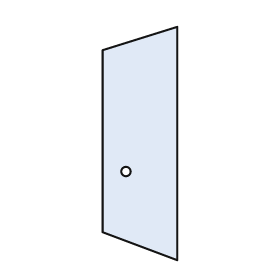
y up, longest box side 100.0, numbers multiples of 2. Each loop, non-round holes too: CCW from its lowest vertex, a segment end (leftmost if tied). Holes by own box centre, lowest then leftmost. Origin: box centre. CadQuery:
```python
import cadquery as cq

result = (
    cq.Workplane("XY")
    .moveTo(16.0, -50.0)
    .lineTo(16.0, 50.0)
    .lineTo(-16.0, 40.0)
    .lineTo(-16.0, -38.0)
    .close()
    .moveTo(-6.0, -12.0)
    .circle(2.0)
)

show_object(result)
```